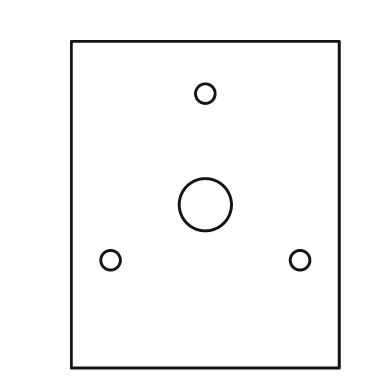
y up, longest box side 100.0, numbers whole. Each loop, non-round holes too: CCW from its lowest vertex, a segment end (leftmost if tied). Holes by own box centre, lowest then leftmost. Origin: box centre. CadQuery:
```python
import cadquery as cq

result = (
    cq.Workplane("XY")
    .moveTo(-41.0, -50.0)
    .lineTo(41.0, -50.0)
    .lineTo(41.0, 50.0)
    .lineTo(-41.0, 50.0)
    .close()
    .moveTo(-29.0, -17.0)
    .circle(3.0)
    .moveTo(29.0, -17.0)
    .circle(3.0)
    .moveTo(0.0, 0.0)
    .circle(8.0)
    .moveTo(0.0, 34.0)
    .circle(3.0)
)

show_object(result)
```